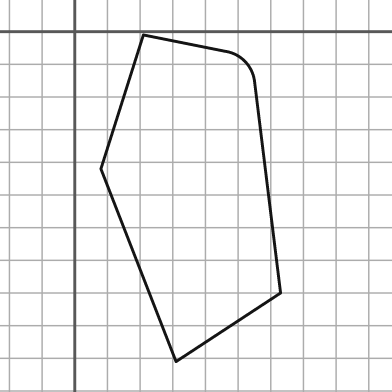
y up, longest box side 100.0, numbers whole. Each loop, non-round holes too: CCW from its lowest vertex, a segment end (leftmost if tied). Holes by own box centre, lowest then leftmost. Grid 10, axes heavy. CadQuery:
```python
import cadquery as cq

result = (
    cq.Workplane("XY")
    .moveTo(31.0, -101.0)
    .lineTo(63.0, -80.0)
    .lineTo(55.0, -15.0)
    .threePointArc((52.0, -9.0), (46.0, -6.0))
    .lineTo(21.0, -1.0)
    .lineTo(8.0, -42.0)
    .close()
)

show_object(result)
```